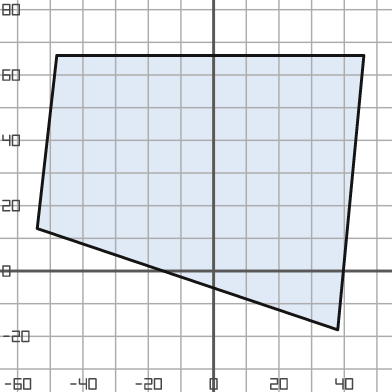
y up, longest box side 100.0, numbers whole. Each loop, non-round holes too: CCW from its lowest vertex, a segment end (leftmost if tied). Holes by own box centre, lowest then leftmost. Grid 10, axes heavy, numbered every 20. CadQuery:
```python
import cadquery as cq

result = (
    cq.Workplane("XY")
    .moveTo(38.0, -18.0)
    .lineTo(46.0, 66.0)
    .lineTo(-48.0, 66.0)
    .lineTo(-54.0, 13.0)
    .close()
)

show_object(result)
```